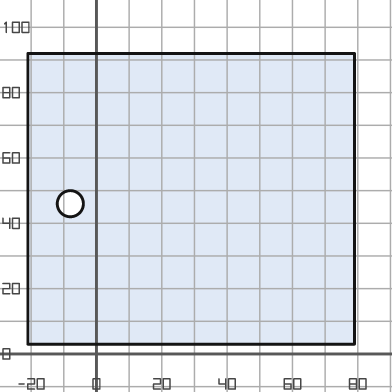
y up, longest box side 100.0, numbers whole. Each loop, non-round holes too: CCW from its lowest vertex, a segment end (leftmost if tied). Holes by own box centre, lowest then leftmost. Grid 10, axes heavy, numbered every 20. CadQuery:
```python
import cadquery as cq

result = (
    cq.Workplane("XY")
    .moveTo(-21.0, 3.0)
    .lineTo(79.0, 3.0)
    .lineTo(79.0, 92.0)
    .lineTo(-21.0, 92.0)
    .close()
    .moveTo(-8.0, 46.0)
    .circle(4.0)
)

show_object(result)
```